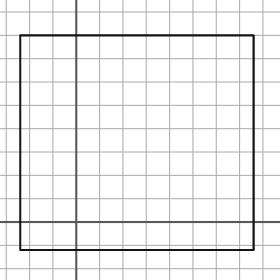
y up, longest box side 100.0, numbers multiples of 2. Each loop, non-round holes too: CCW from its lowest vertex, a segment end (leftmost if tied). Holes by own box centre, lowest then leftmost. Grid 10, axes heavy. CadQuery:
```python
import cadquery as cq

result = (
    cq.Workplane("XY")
    .moveTo(-24.0, -12.0)
    .lineTo(76.0, -12.0)
    .lineTo(76.0, 80.0)
    .lineTo(-24.0, 80.0)
    .close()
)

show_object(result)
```